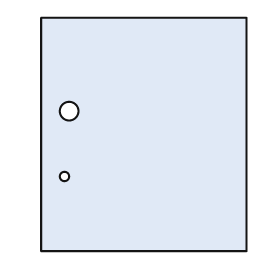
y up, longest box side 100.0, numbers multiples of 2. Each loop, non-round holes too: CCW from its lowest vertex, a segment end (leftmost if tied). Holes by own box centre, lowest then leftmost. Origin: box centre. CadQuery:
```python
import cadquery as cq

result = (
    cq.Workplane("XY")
    .moveTo(-44.0, -50.0)
    .lineTo(44.0, -50.0)
    .lineTo(44.0, 50.0)
    .lineTo(-44.0, 50.0)
    .close()
    .moveTo(-34.0, -18.0)
    .circle(2.0)
    .moveTo(-32.0, 10.0)
    .circle(4.0)
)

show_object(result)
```